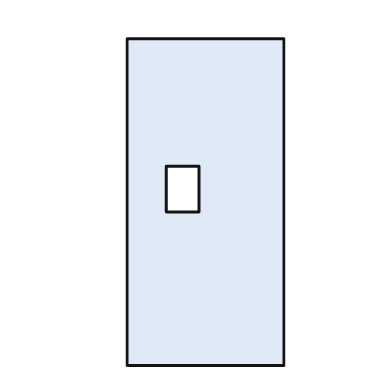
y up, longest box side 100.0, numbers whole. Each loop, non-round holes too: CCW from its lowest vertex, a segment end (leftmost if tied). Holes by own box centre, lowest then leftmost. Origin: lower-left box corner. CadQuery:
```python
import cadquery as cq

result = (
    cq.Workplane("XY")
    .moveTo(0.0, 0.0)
    .lineTo(48.0, 0.0)
    .lineTo(48.0, 100.0)
    .lineTo(0.0, 100.0)
    .close()
    .moveTo(12.0, 47.0)
    .lineTo(22.0, 47.0)
    .lineTo(22.0, 61.0)
    .lineTo(12.0, 61.0)
    .close()
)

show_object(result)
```